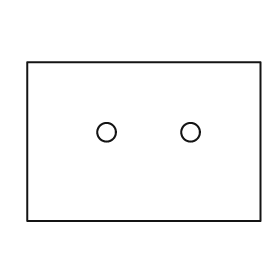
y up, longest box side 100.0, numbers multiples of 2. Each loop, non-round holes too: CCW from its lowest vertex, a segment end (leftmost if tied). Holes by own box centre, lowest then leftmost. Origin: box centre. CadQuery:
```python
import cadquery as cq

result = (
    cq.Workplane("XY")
    .moveTo(-50.0, -34.0)
    .lineTo(50.0, -34.0)
    .lineTo(50.0, 34.0)
    .lineTo(-50.0, 34.0)
    .close()
    .moveTo(-16.0, 4.0)
    .circle(4.0)
    .moveTo(20.0, 4.0)
    .circle(4.0)
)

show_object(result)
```